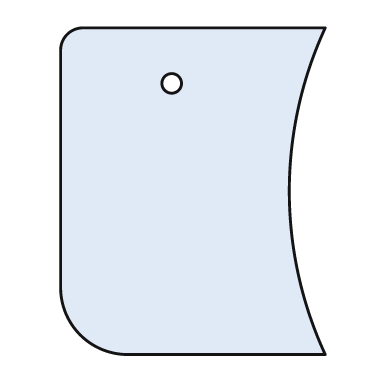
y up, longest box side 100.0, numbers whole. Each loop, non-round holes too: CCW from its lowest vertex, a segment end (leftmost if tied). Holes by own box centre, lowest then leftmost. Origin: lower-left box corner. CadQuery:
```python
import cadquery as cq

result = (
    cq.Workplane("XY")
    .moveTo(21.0, 0.0)
    .lineTo(81.0, 0.0)
    .threePointArc((70.0, 50.0), (81.0, 100.0))
    .lineTo(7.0, 100.0)
    .threePointArc((2.0, 98.0), (0.0, 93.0))
    .lineTo(0.0, 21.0)
    .threePointArc((6.0, 6.0), (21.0, 0.0))
    .close()
    .moveTo(34.0, 83.0)
    .circle(3.0)
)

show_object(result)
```